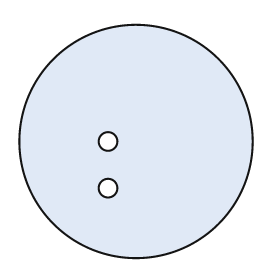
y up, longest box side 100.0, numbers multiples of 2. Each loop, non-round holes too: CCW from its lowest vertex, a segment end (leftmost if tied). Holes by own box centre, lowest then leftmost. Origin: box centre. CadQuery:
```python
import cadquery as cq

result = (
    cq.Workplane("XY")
    .moveTo(0.0, 0.0)
    .circle(50.0)
    .moveTo(-12.0, -20.0)
    .circle(4.0)
    .moveTo(-12.0, 0.0)
    .circle(4.0)
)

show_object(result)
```